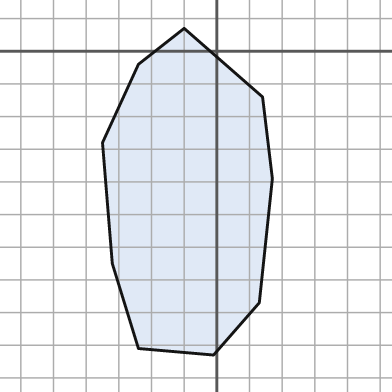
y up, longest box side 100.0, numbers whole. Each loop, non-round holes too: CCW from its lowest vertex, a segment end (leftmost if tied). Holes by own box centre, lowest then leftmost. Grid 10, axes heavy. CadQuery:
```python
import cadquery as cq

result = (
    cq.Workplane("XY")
    .moveTo(-1.0, -93.0)
    .lineTo(13.0, -77.0)
    .lineTo(17.0, -39.0)
    .lineTo(14.0, -14.0)
    .lineTo(-10.0, 7.0)
    .lineTo(-24.0, -4.0)
    .lineTo(-35.0, -28.0)
    .lineTo(-32.0, -65.0)
    .lineTo(-24.0, -91.0)
    .close()
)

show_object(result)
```